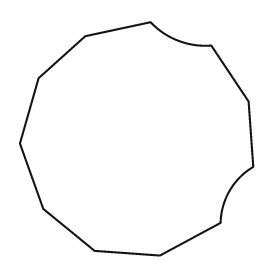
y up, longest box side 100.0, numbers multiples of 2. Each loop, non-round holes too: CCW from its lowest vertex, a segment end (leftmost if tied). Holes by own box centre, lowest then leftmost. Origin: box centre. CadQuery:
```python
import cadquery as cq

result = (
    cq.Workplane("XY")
    .moveTo(10.0, -50.0)
    .lineTo(36.0, -36.0)
    .threePointArc((40.0, -22.0), (50.0, -12.0))
    .lineTo(48.0, 16.0)
    .lineTo(32.0, 40.0)
    .threePointArc((18.0, 42.0), (6.0, 50.0))
    .lineTo(-22.0, 44.0)
    .lineTo(-42.0, 26.0)
    .lineTo(-50.0, -2.0)
    .lineTo(-40.0, -30.0)
    .lineTo(-18.0, -48.0)
    .close()
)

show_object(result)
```